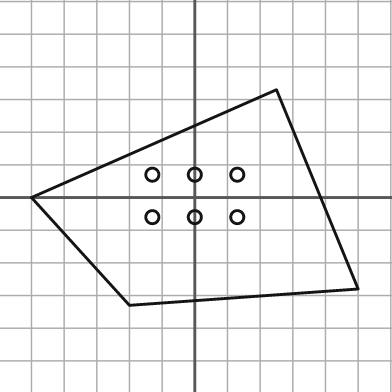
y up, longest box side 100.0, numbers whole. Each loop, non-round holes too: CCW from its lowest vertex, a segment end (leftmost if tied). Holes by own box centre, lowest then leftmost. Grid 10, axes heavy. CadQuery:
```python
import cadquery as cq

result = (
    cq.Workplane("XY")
    .moveTo(-20.0, -33.0)
    .lineTo(50.0, -28.0)
    .lineTo(25.0, 33.0)
    .lineTo(-50.0, 0.0)
    .close()
    .moveTo(-13.0, -6.0)
    .circle(2.0)
    .moveTo(0.0, -6.0)
    .circle(2.0)
    .moveTo(13.0, -6.0)
    .circle(2.0)
    .moveTo(-13.0, 7.0)
    .circle(2.0)
    .moveTo(0.0, 7.0)
    .circle(2.0)
    .moveTo(13.0, 7.0)
    .circle(2.0)
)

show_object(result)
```